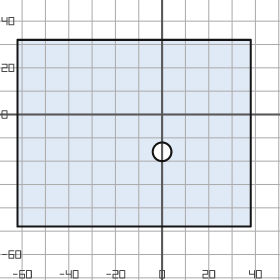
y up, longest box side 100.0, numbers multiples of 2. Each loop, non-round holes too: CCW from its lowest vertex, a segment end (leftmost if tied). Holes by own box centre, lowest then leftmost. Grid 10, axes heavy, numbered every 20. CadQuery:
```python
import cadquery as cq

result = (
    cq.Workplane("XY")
    .moveTo(-62.0, -48.0)
    .lineTo(38.0, -48.0)
    .lineTo(38.0, 32.0)
    .lineTo(-62.0, 32.0)
    .close()
    .moveTo(0.0, -16.0)
    .circle(4.0)
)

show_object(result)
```